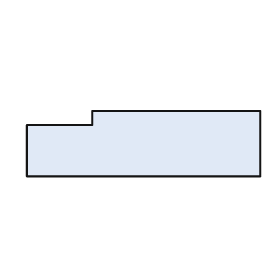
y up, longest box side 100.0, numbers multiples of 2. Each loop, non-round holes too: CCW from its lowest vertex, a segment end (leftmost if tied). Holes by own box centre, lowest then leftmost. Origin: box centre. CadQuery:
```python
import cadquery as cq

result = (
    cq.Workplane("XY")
    .moveTo(-50.0, -14.0)
    .lineTo(50.0, -14.0)
    .lineTo(50.0, 14.0)
    .lineTo(-22.0, 14.0)
    .lineTo(-22.0, 8.0)
    .lineTo(-50.0, 8.0)
    .close()
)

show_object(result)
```